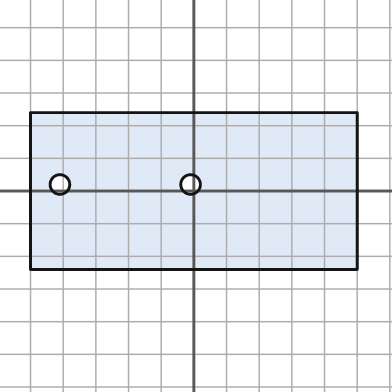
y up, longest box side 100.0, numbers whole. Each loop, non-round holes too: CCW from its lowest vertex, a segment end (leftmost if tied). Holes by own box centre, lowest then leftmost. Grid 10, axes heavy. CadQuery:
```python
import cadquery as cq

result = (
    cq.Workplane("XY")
    .moveTo(-50.0, -24.0)
    .lineTo(50.0, -24.0)
    .lineTo(50.0, 24.0)
    .lineTo(-50.0, 24.0)
    .close()
    .moveTo(-41.0, 2.0)
    .circle(3.0)
    .moveTo(-1.0, 2.0)
    .circle(3.0)
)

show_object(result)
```